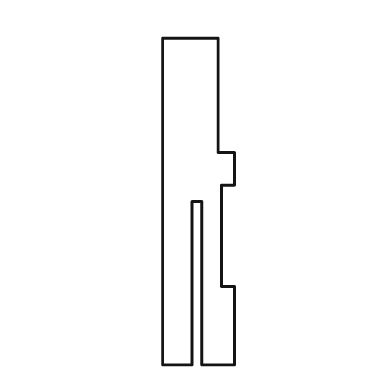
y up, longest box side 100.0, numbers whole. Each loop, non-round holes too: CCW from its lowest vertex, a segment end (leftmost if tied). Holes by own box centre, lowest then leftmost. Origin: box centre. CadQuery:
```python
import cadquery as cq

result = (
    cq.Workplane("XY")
    .moveTo(-11.0, -50.0)
    .lineTo(-2.0, -50.0)
    .lineTo(-2.0, 0.0)
    .lineTo(1.0, 0.0)
    .lineTo(1.0, -50.0)
    .lineTo(11.0, -50.0)
    .lineTo(11.0, -26.0)
    .lineTo(7.0, -26.0)
    .lineTo(7.0, 5.0)
    .lineTo(11.0, 5.0)
    .lineTo(11.0, 15.0)
    .lineTo(6.0, 15.0)
    .lineTo(6.0, 50.0)
    .lineTo(-11.0, 50.0)
    .close()
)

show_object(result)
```